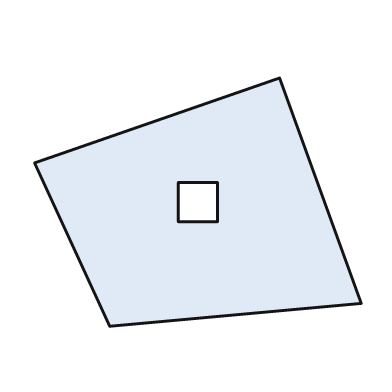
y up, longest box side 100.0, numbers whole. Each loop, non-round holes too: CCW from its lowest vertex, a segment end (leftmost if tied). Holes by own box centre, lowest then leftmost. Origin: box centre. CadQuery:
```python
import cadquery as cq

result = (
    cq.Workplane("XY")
    .moveTo(-27.0, -38.0)
    .lineTo(50.0, -31.0)
    .lineTo(25.0, 38.0)
    .lineTo(-50.0, 12.0)
    .close()
    .moveTo(-6.0, -6.0)
    .lineTo(6.0, -6.0)
    .lineTo(6.0, 6.0)
    .lineTo(-6.0, 6.0)
    .close()
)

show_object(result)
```